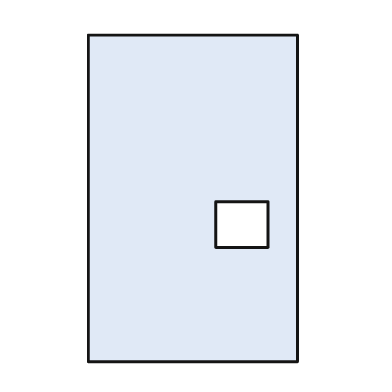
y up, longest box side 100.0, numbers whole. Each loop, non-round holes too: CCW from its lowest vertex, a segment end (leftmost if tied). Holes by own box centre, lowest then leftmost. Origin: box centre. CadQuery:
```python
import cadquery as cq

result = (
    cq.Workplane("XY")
    .moveTo(-32.0, -50.0)
    .lineTo(32.0, -50.0)
    .lineTo(32.0, 50.0)
    .lineTo(-32.0, 50.0)
    .close()
    .moveTo(7.0, -15.0)
    .lineTo(23.0, -15.0)
    .lineTo(23.0, -1.0)
    .lineTo(7.0, -1.0)
    .close()
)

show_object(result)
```